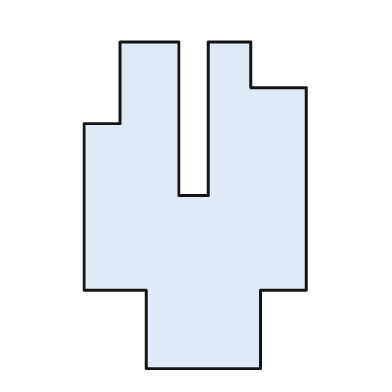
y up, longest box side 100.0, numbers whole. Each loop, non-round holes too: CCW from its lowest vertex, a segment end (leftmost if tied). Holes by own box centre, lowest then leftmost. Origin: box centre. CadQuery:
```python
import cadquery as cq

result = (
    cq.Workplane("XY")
    .moveTo(-15.0, -50.0)
    .lineTo(20.0, -50.0)
    .lineTo(20.0, -26.0)
    .lineTo(34.0, -26.0)
    .lineTo(34.0, 36.0)
    .lineTo(17.0, 36.0)
    .lineTo(17.0, 50.0)
    .lineTo(4.0, 50.0)
    .lineTo(4.0, 3.0)
    .lineTo(-5.0, 3.0)
    .lineTo(-5.0, 50.0)
    .lineTo(-23.0, 50.0)
    .lineTo(-23.0, 25.0)
    .lineTo(-34.0, 25.0)
    .lineTo(-34.0, -26.0)
    .lineTo(-15.0, -26.0)
    .close()
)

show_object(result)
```